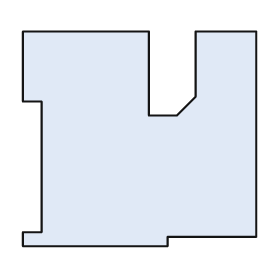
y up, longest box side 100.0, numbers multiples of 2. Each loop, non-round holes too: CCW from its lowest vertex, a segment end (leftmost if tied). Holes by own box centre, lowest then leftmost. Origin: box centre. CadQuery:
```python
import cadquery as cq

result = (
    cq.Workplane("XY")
    .moveTo(-50.0, -46.0)
    .lineTo(12.0, -46.0)
    .lineTo(12.0, -42.0)
    .lineTo(50.0, -42.0)
    .lineTo(50.0, 46.0)
    .lineTo(24.0, 46.0)
    .lineTo(24.0, 18.0)
    .lineTo(16.0, 10.0)
    .lineTo(4.0, 10.0)
    .lineTo(4.0, 46.0)
    .lineTo(-50.0, 46.0)
    .lineTo(-50.0, 16.0)
    .lineTo(-42.0, 16.0)
    .lineTo(-42.0, -40.0)
    .lineTo(-50.0, -40.0)
    .close()
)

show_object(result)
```